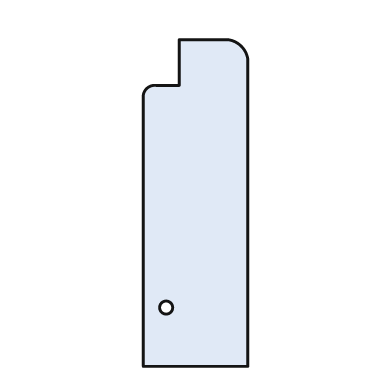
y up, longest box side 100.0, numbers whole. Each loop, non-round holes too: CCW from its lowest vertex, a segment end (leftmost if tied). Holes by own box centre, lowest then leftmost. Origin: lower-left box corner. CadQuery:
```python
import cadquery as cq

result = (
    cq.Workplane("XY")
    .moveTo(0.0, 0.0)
    .lineTo(32.0, 0.0)
    .lineTo(32.0, 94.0)
    .threePointArc((30.0, 98.0), (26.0, 100.0))
    .lineTo(11.0, 100.0)
    .lineTo(11.0, 86.0)
    .lineTo(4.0, 86.0)
    .threePointArc((1.0, 85.0), (0.0, 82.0))
    .close()
    .moveTo(7.0, 18.0)
    .circle(2.0)
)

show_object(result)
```